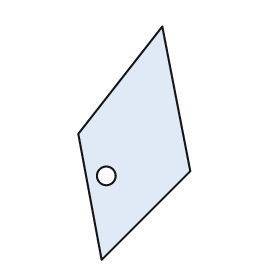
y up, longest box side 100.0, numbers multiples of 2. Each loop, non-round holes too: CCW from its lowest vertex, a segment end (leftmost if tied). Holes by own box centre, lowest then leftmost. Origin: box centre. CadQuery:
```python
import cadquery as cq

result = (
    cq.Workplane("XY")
    .moveTo(-14.0, -50.0)
    .lineTo(24.0, -12.0)
    .lineTo(12.0, 50.0)
    .lineTo(-24.0, 4.0)
    .close()
    .moveTo(-12.0, -14.0)
    .circle(4.0)
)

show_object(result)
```